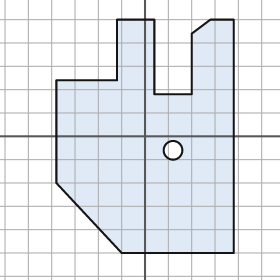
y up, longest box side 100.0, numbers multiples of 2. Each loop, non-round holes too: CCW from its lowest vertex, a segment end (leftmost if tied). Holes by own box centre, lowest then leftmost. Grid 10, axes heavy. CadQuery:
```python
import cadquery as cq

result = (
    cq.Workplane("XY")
    .moveTo(-10.0, -50.0)
    .lineTo(38.0, -50.0)
    .lineTo(38.0, 50.0)
    .lineTo(28.0, 50.0)
    .lineTo(20.0, 44.0)
    .lineTo(20.0, 18.0)
    .lineTo(4.0, 18.0)
    .lineTo(4.0, 50.0)
    .lineTo(-12.0, 50.0)
    .lineTo(-12.0, 24.0)
    .lineTo(-38.0, 24.0)
    .lineTo(-38.0, -20.0)
    .close()
    .moveTo(12.0, -6.0)
    .circle(4.0)
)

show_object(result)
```